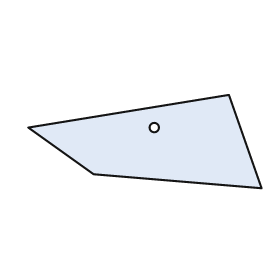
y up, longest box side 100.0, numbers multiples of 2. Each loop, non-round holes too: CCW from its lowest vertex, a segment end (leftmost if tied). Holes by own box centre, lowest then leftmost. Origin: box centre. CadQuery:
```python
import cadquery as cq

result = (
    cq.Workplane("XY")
    .moveTo(50.0, -20.0)
    .lineTo(36.0, 20.0)
    .lineTo(-50.0, 6.0)
    .lineTo(-22.0, -14.0)
    .close()
    .moveTo(4.0, 6.0)
    .circle(2.0)
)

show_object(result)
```